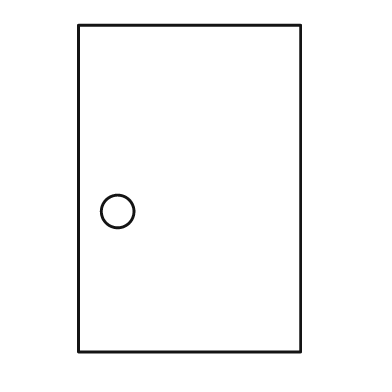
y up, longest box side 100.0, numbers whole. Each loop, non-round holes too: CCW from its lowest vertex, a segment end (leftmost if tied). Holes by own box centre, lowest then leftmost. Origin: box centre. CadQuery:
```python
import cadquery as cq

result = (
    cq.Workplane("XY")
    .moveTo(-34.0, -50.0)
    .lineTo(34.0, -50.0)
    .lineTo(34.0, 50.0)
    .lineTo(-34.0, 50.0)
    .close()
    .moveTo(-22.0, -7.0)
    .circle(5.0)
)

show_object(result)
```